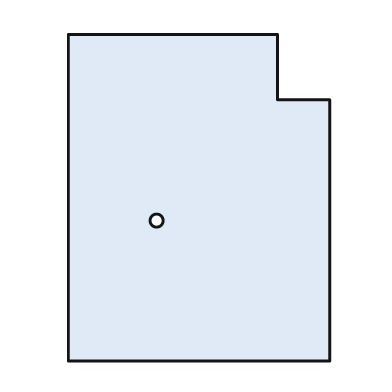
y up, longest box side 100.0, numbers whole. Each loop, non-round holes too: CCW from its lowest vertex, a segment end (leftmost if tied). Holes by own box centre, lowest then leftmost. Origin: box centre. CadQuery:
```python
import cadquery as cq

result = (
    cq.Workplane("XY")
    .moveTo(-40.0, -50.0)
    .lineTo(40.0, -50.0)
    .lineTo(40.0, 30.0)
    .lineTo(24.0, 30.0)
    .lineTo(24.0, 50.0)
    .lineTo(-40.0, 50.0)
    .close()
    .moveTo(-13.0, -7.0)
    .circle(2.0)
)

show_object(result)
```